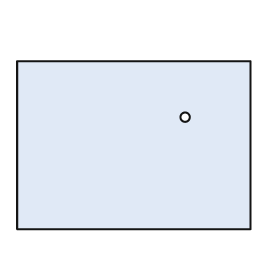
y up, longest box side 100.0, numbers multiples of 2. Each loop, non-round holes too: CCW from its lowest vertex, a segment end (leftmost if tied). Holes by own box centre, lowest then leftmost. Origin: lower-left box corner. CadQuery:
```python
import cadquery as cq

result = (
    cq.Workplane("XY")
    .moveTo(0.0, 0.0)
    .lineTo(100.0, 0.0)
    .lineTo(100.0, 72.0)
    .lineTo(0.0, 72.0)
    .close()
    .moveTo(72.0, 48.0)
    .circle(2.0)
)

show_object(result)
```